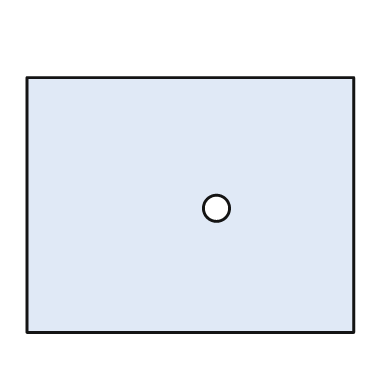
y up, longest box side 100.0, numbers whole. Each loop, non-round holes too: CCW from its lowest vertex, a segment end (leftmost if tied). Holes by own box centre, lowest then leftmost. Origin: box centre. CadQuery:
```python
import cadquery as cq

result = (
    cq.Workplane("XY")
    .moveTo(-50.0, -39.0)
    .lineTo(50.0, -39.0)
    .lineTo(50.0, 39.0)
    .lineTo(-50.0, 39.0)
    .close()
    .moveTo(8.0, -1.0)
    .circle(4.0)
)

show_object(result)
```